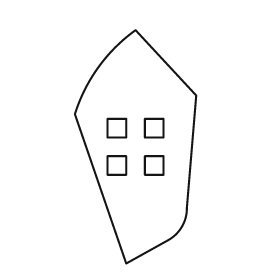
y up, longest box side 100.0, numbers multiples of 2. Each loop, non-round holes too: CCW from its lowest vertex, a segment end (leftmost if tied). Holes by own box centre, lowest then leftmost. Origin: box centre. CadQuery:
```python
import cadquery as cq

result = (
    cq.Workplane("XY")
    .moveTo(-4.0, -50.0)
    .lineTo(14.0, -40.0)
    .threePointArc((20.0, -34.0), (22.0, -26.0))
    .lineTo(26.0, 22.0)
    .lineTo(0.0, 50.0)
    .threePointArc((-16.0, 34.0), (-26.0, 14.0))
    .close()
    .moveTo(-12.0, -12.0)
    .lineTo(-4.0, -12.0)
    .lineTo(-4.0, -4.0)
    .lineTo(-12.0, -4.0)
    .close()
    .moveTo(4.0, -12.0)
    .lineTo(12.0, -12.0)
    .lineTo(12.0, -4.0)
    .lineTo(4.0, -4.0)
    .close()
    .moveTo(-12.0, 4.0)
    .lineTo(-4.0, 4.0)
    .lineTo(-4.0, 12.0)
    .lineTo(-12.0, 12.0)
    .close()
    .moveTo(4.0, 4.0)
    .lineTo(12.0, 4.0)
    .lineTo(12.0, 12.0)
    .lineTo(4.0, 12.0)
    .close()
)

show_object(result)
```